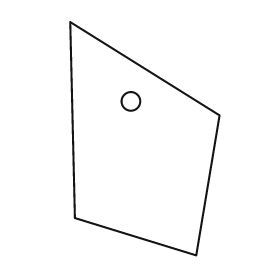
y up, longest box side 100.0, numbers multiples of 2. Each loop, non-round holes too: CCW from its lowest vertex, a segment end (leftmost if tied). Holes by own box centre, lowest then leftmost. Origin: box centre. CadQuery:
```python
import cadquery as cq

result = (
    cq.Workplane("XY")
    .moveTo(22.0, -50.0)
    .lineTo(32.0, 10.0)
    .lineTo(-32.0, 50.0)
    .lineTo(-30.0, -34.0)
    .close()
    .moveTo(-6.0, 16.0)
    .circle(4.0)
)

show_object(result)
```